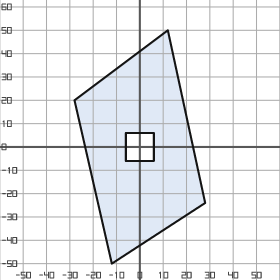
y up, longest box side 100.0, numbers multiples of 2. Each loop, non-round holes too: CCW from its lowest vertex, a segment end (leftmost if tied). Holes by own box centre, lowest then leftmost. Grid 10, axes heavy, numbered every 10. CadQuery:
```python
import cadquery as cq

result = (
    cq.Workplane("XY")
    .moveTo(-12.0, -50.0)
    .lineTo(28.0, -24.0)
    .lineTo(12.0, 50.0)
    .lineTo(-28.0, 20.0)
    .close()
    .moveTo(-6.0, -6.0)
    .lineTo(6.0, -6.0)
    .lineTo(6.0, 6.0)
    .lineTo(-6.0, 6.0)
    .close()
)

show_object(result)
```